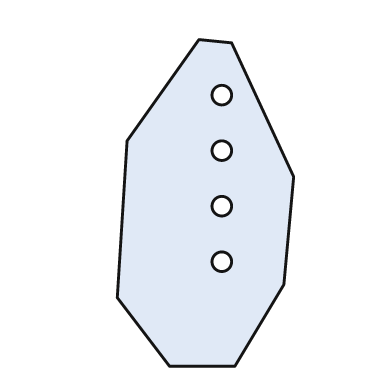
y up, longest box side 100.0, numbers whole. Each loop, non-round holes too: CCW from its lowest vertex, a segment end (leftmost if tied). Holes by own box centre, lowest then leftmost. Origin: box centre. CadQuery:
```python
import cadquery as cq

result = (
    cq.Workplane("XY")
    .moveTo(-11.0, -50.0)
    .lineTo(9.0, -50.0)
    .lineTo(24.0, -25.0)
    .lineTo(27.0, 8.0)
    .lineTo(8.0, 49.0)
    .lineTo(-2.0, 50.0)
    .lineTo(-24.0, 19.0)
    .lineTo(-27.0, -29.0)
    .close()
    .moveTo(5.0, -18.0)
    .circle(3.0)
    .moveTo(5.0, -1.0)
    .circle(3.0)
    .moveTo(5.0, 16.0)
    .circle(3.0)
    .moveTo(5.0, 33.0)
    .circle(3.0)
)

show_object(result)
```